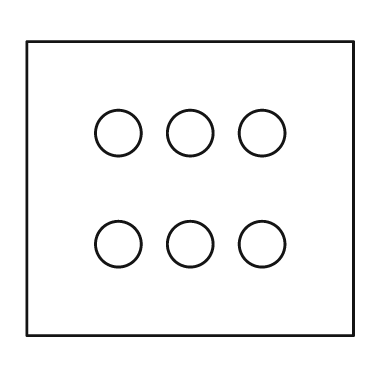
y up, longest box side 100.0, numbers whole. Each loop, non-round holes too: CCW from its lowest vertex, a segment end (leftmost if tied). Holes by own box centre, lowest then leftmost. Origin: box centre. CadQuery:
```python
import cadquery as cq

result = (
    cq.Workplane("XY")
    .moveTo(-50.0, -45.0)
    .lineTo(50.0, -45.0)
    .lineTo(50.0, 45.0)
    .lineTo(-50.0, 45.0)
    .close()
    .moveTo(-22.0, -17.0)
    .circle(7.0)
    .moveTo(0.0, -17.0)
    .circle(7.0)
    .moveTo(22.0, -17.0)
    .circle(7.0)
    .moveTo(-22.0, 17.0)
    .circle(7.0)
    .moveTo(0.0, 17.0)
    .circle(7.0)
    .moveTo(22.0, 17.0)
    .circle(7.0)
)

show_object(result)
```